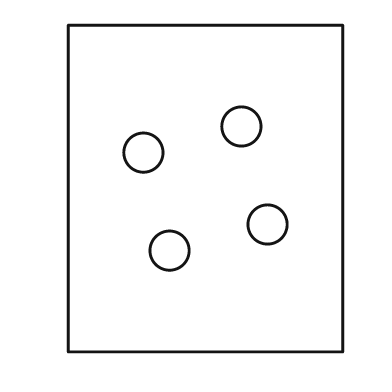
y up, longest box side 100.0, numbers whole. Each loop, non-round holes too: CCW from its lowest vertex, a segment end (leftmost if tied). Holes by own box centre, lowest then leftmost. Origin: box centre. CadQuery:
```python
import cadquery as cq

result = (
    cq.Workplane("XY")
    .moveTo(-42.0, -50.0)
    .lineTo(42.0, -50.0)
    .lineTo(42.0, 50.0)
    .lineTo(-42.0, 50.0)
    .close()
    .moveTo(-11.0, -19.0)
    .circle(6.0)
    .moveTo(19.0, -11.0)
    .circle(6.0)
    .moveTo(-19.0, 11.0)
    .circle(6.0)
    .moveTo(11.0, 19.0)
    .circle(6.0)
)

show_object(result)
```